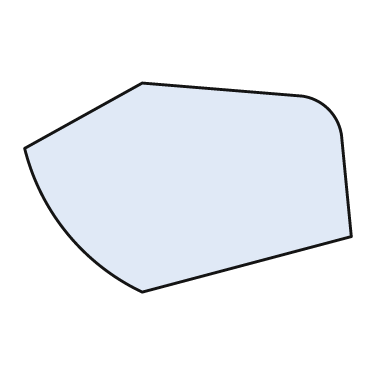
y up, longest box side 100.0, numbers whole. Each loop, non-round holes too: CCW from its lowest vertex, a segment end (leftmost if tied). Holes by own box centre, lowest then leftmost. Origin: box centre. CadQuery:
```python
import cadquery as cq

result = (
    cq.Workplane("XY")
    .moveTo(-14.0, -32.0)
    .lineTo(50.0, -15.0)
    .lineTo(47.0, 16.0)
    .threePointArc((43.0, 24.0), (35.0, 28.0))
    .lineTo(-14.0, 32.0)
    .lineTo(-50.0, 12.0)
    .threePointArc((-37.0, -14.0), (-14.0, -32.0))
    .close()
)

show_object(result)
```